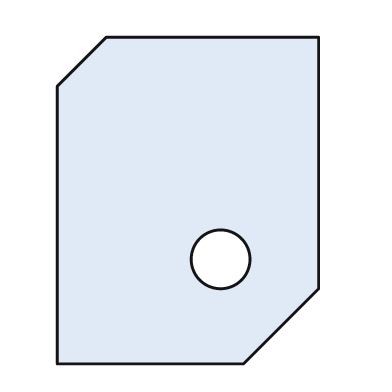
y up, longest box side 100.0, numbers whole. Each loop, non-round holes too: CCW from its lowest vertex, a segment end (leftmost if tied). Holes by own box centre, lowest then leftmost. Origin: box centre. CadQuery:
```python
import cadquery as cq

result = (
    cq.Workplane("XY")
    .moveTo(-40.0, -50.0)
    .lineTo(17.0, -50.0)
    .lineTo(40.0, -27.0)
    .lineTo(40.0, 50.0)
    .lineTo(-25.0, 50.0)
    .lineTo(-40.0, 35.0)
    .close()
    .moveTo(10.0, -18.0)
    .circle(9.0)
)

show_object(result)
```